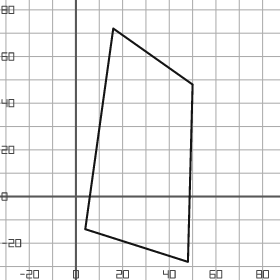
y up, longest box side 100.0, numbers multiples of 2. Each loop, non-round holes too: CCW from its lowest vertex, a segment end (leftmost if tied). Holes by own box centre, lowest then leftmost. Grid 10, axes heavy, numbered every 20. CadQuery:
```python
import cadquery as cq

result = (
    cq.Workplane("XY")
    .moveTo(48.0, -28.0)
    .lineTo(50.0, 48.0)
    .lineTo(16.0, 72.0)
    .lineTo(4.0, -14.0)
    .close()
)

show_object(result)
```